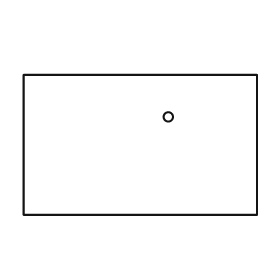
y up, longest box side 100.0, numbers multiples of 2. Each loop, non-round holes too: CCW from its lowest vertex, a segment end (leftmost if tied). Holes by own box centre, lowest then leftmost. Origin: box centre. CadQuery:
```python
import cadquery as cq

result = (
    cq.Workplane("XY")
    .moveTo(-50.0, -30.0)
    .lineTo(50.0, -30.0)
    .lineTo(50.0, 30.0)
    .lineTo(-50.0, 30.0)
    .close()
    .moveTo(12.0, 12.0)
    .circle(2.0)
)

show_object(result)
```